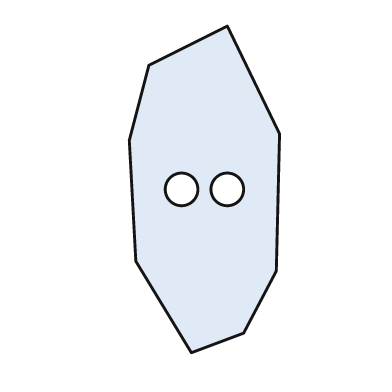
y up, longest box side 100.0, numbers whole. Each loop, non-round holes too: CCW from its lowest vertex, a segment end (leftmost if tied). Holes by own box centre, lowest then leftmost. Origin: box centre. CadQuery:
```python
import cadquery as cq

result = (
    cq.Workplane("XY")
    .moveTo(-4.0, -50.0)
    .lineTo(12.0, -44.0)
    .lineTo(22.0, -25.0)
    .lineTo(23.0, 17.0)
    .lineTo(7.0, 50.0)
    .lineTo(-17.0, 38.0)
    .lineTo(-23.0, 15.0)
    .lineTo(-21.0, -22.0)
    .close()
    .moveTo(-7.0, 0.0)
    .circle(5.0)
    .moveTo(7.0, 0.0)
    .circle(5.0)
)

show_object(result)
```